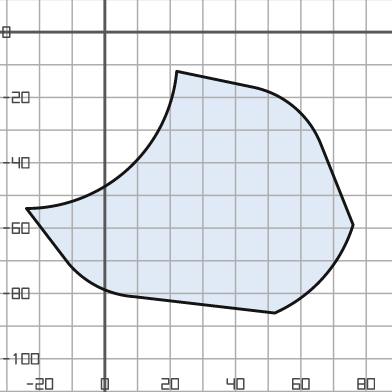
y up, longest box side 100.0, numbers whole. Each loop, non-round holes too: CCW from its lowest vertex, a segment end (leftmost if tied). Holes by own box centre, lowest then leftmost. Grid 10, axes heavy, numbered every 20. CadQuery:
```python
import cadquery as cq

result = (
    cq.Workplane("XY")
    .moveTo(52.0, -86.0)
    .threePointArc((67.0, -75.0), (76.0, -59.0))
    .lineTo(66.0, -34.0)
    .threePointArc((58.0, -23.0), (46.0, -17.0))
    .lineTo(22.0, -12.0)
    .threePointArc((7.0, -42.0), (-24.0, -54.0))
    .lineTo(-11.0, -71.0)
    .threePointArc((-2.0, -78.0), (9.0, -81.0))
    .close()
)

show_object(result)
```